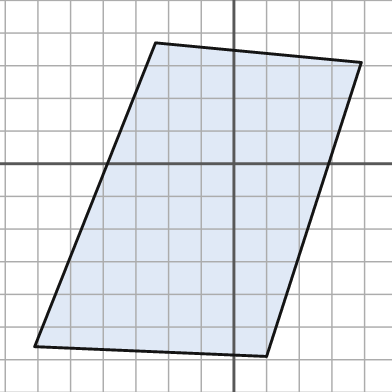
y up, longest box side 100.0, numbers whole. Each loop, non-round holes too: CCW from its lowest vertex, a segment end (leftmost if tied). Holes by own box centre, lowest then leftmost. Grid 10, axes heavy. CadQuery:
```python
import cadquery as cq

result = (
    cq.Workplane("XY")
    .moveTo(10.0, -59.0)
    .lineTo(39.0, 31.0)
    .lineTo(-24.0, 37.0)
    .lineTo(-61.0, -56.0)
    .close()
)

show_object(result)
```